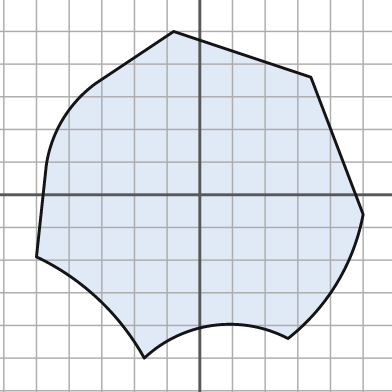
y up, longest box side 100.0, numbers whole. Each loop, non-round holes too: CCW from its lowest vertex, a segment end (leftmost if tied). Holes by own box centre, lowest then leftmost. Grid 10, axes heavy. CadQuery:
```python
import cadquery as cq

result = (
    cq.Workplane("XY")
    .moveTo(-17.0, -50.0)
    .threePointArc((4.0, -40.0), (27.0, -44.0))
    .threePointArc((42.0, -27.0), (50.0, -6.0))
    .lineTo(34.0, 36.0)
    .lineTo(-8.0, 50.0)
    .lineTo(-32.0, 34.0)
    .threePointArc((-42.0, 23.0), (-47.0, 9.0))
    .lineTo(-50.0, -19.0)
    .threePointArc((-31.0, -32.0), (-17.0, -50.0))
    .close()
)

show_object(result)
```